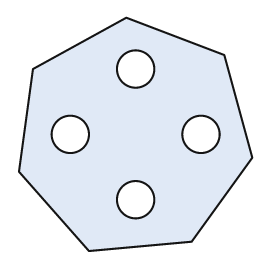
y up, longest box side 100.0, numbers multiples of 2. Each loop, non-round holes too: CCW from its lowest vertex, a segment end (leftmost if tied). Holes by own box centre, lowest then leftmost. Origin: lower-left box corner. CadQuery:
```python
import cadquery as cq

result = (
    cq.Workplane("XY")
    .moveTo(30.0, 0.0)
    .lineTo(74.0, 4.0)
    .lineTo(100.0, 40.0)
    .lineTo(88.0, 84.0)
    .lineTo(46.0, 100.0)
    .lineTo(6.0, 78.0)
    .lineTo(0.0, 34.0)
    .close()
    .moveTo(50.0, 22.0)
    .circle(8.0)
    .moveTo(22.0, 50.0)
    .circle(8.0)
    .moveTo(78.0, 50.0)
    .circle(8.0)
    .moveTo(50.0, 78.0)
    .circle(8.0)
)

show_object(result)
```